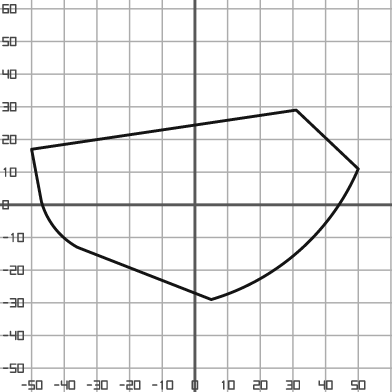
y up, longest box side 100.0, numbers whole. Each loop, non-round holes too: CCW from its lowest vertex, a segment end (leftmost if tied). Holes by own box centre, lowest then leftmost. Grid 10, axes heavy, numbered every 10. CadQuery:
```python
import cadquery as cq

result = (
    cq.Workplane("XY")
    .moveTo(5.0, -29.0)
    .threePointArc((32.0, -14.0), (50.0, 11.0))
    .lineTo(31.0, 29.0)
    .lineTo(-50.0, 17.0)
    .lineTo(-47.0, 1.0)
    .threePointArc((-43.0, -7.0), (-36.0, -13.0))
    .close()
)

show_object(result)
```